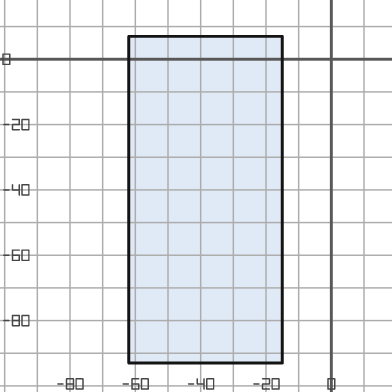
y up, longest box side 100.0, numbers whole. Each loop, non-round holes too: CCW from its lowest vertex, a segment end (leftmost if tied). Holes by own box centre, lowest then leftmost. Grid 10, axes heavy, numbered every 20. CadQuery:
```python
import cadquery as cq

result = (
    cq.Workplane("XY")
    .moveTo(-62.0, -93.0)
    .lineTo(-15.0, -93.0)
    .lineTo(-15.0, 7.0)
    .lineTo(-62.0, 7.0)
    .close()
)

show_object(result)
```